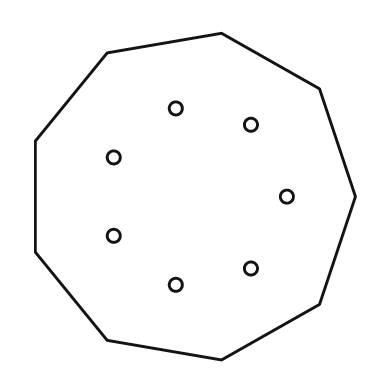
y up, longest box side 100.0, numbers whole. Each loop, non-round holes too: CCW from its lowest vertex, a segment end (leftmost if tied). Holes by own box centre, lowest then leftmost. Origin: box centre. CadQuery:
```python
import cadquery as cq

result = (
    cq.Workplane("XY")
    .moveTo(8.0, -50.0)
    .lineTo(38.0, -33.0)
    .lineTo(49.0, 0.0)
    .lineTo(38.0, 33.0)
    .lineTo(8.0, 50.0)
    .lineTo(-27.0, 44.0)
    .lineTo(-49.0, 17.0)
    .lineTo(-49.0, -17.0)
    .lineTo(-27.0, -44.0)
    .close()
    .moveTo(-6.0, -27.0)
    .circle(2.0)
    .moveTo(17.0, -22.0)
    .circle(2.0)
    .moveTo(-25.0, -12.0)
    .circle(2.0)
    .moveTo(28.0, 0.0)
    .circle(2.0)
    .moveTo(-25.0, 12.0)
    .circle(2.0)
    .moveTo(17.0, 22.0)
    .circle(2.0)
    .moveTo(-6.0, 27.0)
    .circle(2.0)
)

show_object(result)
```